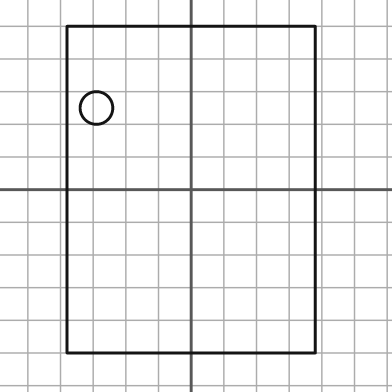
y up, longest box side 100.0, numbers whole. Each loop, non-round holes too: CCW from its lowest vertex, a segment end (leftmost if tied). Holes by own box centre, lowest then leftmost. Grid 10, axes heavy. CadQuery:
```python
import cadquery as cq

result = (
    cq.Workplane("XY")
    .moveTo(-38.0, -50.0)
    .lineTo(38.0, -50.0)
    .lineTo(38.0, 50.0)
    .lineTo(-38.0, 50.0)
    .close()
    .moveTo(-29.0, 25.0)
    .circle(5.0)
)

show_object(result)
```